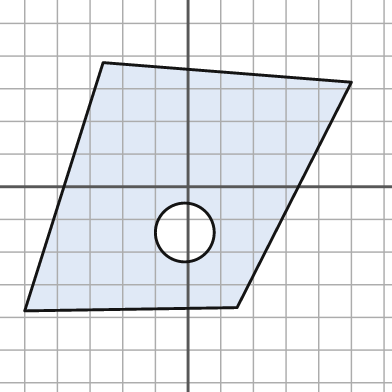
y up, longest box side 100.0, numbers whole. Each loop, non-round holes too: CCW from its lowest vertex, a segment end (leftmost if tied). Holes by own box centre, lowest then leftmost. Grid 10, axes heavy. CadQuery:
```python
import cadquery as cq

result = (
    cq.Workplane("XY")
    .moveTo(-50.0, -38.0)
    .lineTo(15.0, -37.0)
    .lineTo(50.0, 32.0)
    .lineTo(-26.0, 38.0)
    .close()
    .moveTo(-1.0, -14.0)
    .circle(9.0)
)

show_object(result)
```